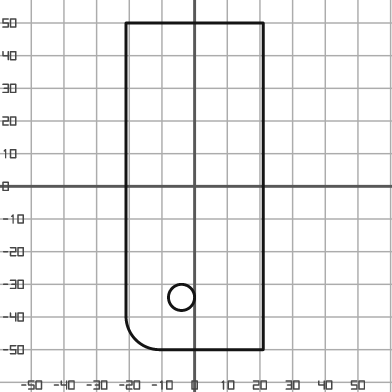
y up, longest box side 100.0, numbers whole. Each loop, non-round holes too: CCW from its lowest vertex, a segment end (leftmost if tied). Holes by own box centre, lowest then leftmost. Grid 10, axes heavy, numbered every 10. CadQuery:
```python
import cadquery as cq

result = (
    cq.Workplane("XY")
    .moveTo(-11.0, -50.0)
    .lineTo(21.0, -50.0)
    .lineTo(21.0, 50.0)
    .lineTo(-21.0, 50.0)
    .lineTo(-21.0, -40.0)
    .threePointArc((-18.0, -47.0), (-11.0, -50.0))
    .close()
    .moveTo(-4.0, -34.0)
    .circle(4.0)
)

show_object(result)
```